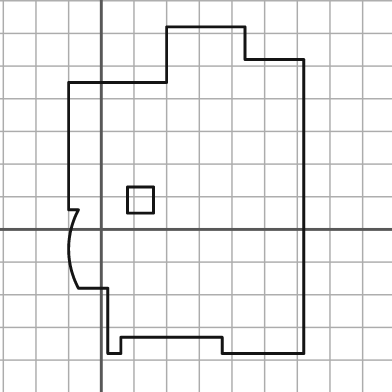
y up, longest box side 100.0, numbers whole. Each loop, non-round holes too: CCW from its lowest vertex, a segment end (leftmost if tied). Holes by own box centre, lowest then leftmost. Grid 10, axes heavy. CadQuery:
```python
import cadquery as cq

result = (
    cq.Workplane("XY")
    .moveTo(2.0, -38.0)
    .lineTo(6.0, -38.0)
    .lineTo(6.0, -33.0)
    .lineTo(37.0, -33.0)
    .lineTo(37.0, -38.0)
    .lineTo(62.0, -38.0)
    .lineTo(62.0, 52.0)
    .lineTo(44.0, 52.0)
    .lineTo(44.0, 62.0)
    .lineTo(20.0, 62.0)
    .lineTo(20.0, 45.0)
    .lineTo(-10.0, 45.0)
    .lineTo(-10.0, 6.0)
    .lineTo(-7.0, 6.0)
    .threePointArc((-10.0, -6.0), (-7.0, -18.0))
    .lineTo(2.0, -18.0)
    .close()
    .moveTo(8.0, 5.0)
    .lineTo(16.0, 5.0)
    .lineTo(16.0, 13.0)
    .lineTo(8.0, 13.0)
    .close()
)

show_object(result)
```